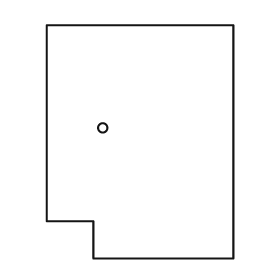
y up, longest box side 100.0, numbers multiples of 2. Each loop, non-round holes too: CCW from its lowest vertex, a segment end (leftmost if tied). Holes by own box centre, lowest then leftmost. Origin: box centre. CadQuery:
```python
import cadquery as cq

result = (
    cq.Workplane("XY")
    .moveTo(-20.0, -50.0)
    .lineTo(40.0, -50.0)
    .lineTo(40.0, 50.0)
    .lineTo(-40.0, 50.0)
    .lineTo(-40.0, -34.0)
    .lineTo(-20.0, -34.0)
    .close()
    .moveTo(-16.0, 6.0)
    .circle(2.0)
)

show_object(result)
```